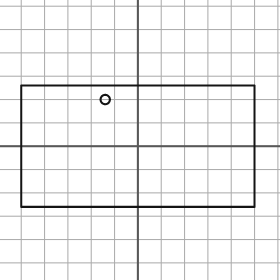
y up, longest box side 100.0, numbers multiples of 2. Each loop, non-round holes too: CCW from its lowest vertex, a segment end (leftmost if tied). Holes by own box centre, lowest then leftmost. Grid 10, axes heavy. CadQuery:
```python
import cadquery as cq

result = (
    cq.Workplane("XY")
    .moveTo(-50.0, -26.0)
    .lineTo(50.0, -26.0)
    .lineTo(50.0, 26.0)
    .lineTo(-50.0, 26.0)
    .close()
    .moveTo(-14.0, 20.0)
    .circle(2.0)
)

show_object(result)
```